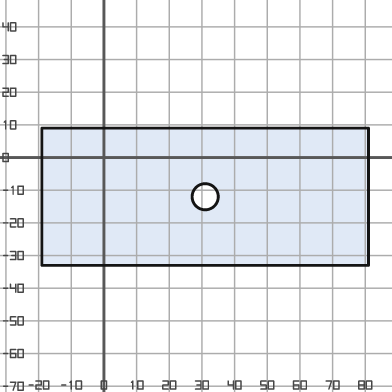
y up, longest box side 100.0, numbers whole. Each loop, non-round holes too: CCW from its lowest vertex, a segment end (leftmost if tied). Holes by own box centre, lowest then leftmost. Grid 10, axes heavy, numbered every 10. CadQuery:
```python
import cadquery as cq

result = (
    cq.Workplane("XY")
    .moveTo(-19.0, -33.0)
    .lineTo(81.0, -33.0)
    .lineTo(81.0, 9.0)
    .lineTo(-19.0, 9.0)
    .close()
    .moveTo(31.0, -12.0)
    .circle(4.0)
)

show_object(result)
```